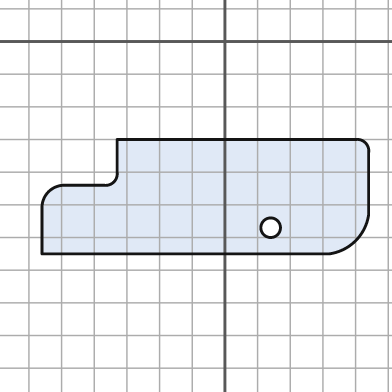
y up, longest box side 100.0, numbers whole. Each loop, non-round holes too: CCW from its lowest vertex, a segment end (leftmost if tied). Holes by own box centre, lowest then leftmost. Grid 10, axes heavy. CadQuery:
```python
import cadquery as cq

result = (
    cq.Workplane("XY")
    .moveTo(-56.0, -65.0)
    .lineTo(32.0, -65.0)
    .threePointArc((40.0, -61.0), (44.0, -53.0))
    .lineTo(44.0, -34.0)
    .threePointArc((43.0, -31.0), (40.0, -30.0))
    .lineTo(-33.0, -30.0)
    .lineTo(-33.0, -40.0)
    .threePointArc((-34.0, -43.0), (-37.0, -44.0))
    .lineTo(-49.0, -44.0)
    .threePointArc((-54.0, -46.0), (-56.0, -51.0))
    .close()
    .moveTo(14.0, -57.0)
    .circle(3.0)
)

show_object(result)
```